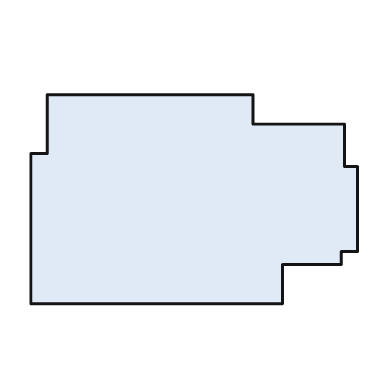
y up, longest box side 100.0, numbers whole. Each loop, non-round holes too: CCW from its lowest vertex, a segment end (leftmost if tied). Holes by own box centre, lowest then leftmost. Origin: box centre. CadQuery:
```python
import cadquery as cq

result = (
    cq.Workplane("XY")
    .moveTo(-50.0, -32.0)
    .lineTo(27.0, -32.0)
    .lineTo(27.0, -20.0)
    .lineTo(45.0, -20.0)
    .lineTo(45.0, -16.0)
    .lineTo(50.0, -16.0)
    .lineTo(50.0, 10.0)
    .lineTo(46.0, 10.0)
    .lineTo(46.0, 23.0)
    .lineTo(18.0, 23.0)
    .lineTo(18.0, 32.0)
    .lineTo(-45.0, 32.0)
    .lineTo(-45.0, 14.0)
    .lineTo(-50.0, 14.0)
    .close()
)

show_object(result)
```